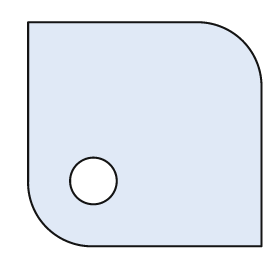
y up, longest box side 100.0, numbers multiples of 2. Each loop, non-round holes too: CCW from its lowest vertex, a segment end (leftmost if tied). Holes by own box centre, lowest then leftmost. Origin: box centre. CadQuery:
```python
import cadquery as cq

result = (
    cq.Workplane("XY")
    .moveTo(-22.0, -48.0)
    .lineTo(50.0, -48.0)
    .lineTo(50.0, 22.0)
    .threePointArc((42.0, 40.0), (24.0, 48.0))
    .lineTo(-50.0, 48.0)
    .lineTo(-50.0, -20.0)
    .threePointArc((-42.0, -40.0), (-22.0, -48.0))
    .close()
    .moveTo(-22.0, -20.0)
    .circle(10.0)
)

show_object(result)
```